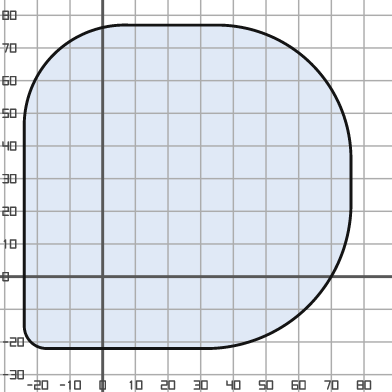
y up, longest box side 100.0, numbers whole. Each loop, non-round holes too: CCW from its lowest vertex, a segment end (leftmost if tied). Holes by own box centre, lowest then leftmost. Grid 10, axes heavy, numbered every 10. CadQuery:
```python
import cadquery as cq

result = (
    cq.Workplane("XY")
    .moveTo(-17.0, -22.0)
    .lineTo(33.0, -22.0)
    .threePointArc((63.0, -9.0), (76.0, 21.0))
    .lineTo(76.0, 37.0)
    .threePointArc((64.0, 65.0), (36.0, 77.0))
    .lineTo(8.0, 77.0)
    .threePointArc((-15.0, 68.0), (-24.0, 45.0))
    .lineTo(-24.0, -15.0)
    .threePointArc((-22.0, -20.0), (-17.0, -22.0))
    .close()
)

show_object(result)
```